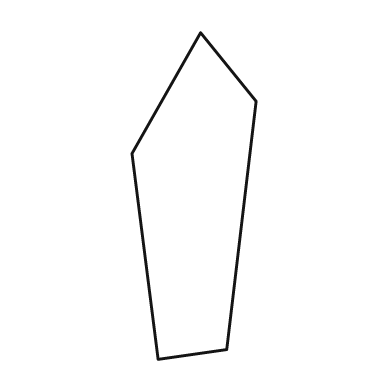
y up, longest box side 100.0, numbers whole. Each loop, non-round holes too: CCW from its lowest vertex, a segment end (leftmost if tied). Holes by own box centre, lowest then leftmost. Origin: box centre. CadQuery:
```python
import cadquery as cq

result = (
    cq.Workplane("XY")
    .moveTo(-11.0, -50.0)
    .lineTo(10.0, -47.0)
    .lineTo(19.0, 29.0)
    .lineTo(2.0, 50.0)
    .lineTo(-19.0, 13.0)
    .close()
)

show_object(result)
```